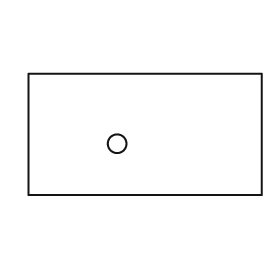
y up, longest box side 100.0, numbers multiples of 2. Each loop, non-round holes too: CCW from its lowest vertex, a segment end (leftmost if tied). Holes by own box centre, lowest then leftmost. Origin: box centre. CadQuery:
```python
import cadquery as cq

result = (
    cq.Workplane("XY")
    .moveTo(-50.0, -26.0)
    .lineTo(50.0, -26.0)
    .lineTo(50.0, 26.0)
    .lineTo(-50.0, 26.0)
    .close()
    .moveTo(-12.0, -4.0)
    .circle(4.0)
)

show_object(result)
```